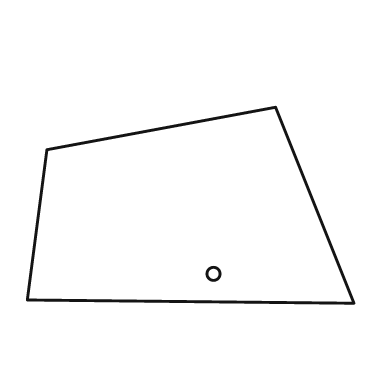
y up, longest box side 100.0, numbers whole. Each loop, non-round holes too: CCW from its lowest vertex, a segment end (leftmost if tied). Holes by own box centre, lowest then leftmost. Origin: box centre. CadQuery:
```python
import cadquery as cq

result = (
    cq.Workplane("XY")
    .moveTo(50.0, -30.0)
    .lineTo(26.0, 30.0)
    .lineTo(-44.0, 17.0)
    .lineTo(-50.0, -29.0)
    .close()
    .moveTo(7.0, -21.0)
    .circle(2.0)
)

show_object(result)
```